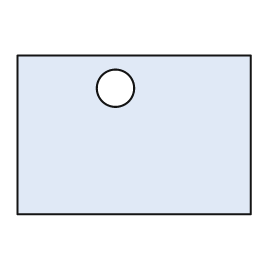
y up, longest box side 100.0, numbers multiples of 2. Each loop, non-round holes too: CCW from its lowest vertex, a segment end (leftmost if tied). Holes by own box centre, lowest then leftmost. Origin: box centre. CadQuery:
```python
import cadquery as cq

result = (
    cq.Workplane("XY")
    .moveTo(-50.0, -34.0)
    .lineTo(50.0, -34.0)
    .lineTo(50.0, 34.0)
    .lineTo(-50.0, 34.0)
    .close()
    .moveTo(-8.0, 20.0)
    .circle(8.0)
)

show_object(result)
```